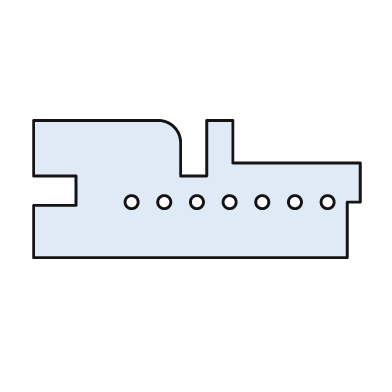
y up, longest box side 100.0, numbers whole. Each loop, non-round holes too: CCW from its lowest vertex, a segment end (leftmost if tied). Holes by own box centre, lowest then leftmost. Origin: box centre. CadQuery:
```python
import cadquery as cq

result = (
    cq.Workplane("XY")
    .moveTo(-50.0, -21.0)
    .lineTo(46.0, -21.0)
    .lineTo(46.0, -4.0)
    .lineTo(50.0, -4.0)
    .lineTo(50.0, 8.0)
    .lineTo(11.0, 8.0)
    .lineTo(11.0, 21.0)
    .lineTo(3.0, 21.0)
    .lineTo(3.0, 4.0)
    .lineTo(-5.0, 4.0)
    .lineTo(-5.0, 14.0)
    .threePointArc((-7.0, 19.0), (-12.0, 21.0))
    .lineTo(-50.0, 21.0)
    .lineTo(-50.0, 4.0)
    .lineTo(-37.0, 4.0)
    .lineTo(-37.0, -5.0)
    .lineTo(-50.0, -5.0)
    .close()
    .moveTo(-20.0, -4.0)
    .circle(2.0)
    .moveTo(-10.0, -4.0)
    .circle(2.0)
    .moveTo(0.0, -4.0)
    .circle(2.0)
    .moveTo(10.0, -4.0)
    .circle(2.0)
    .moveTo(20.0, -4.0)
    .circle(2.0)
    .moveTo(30.0, -4.0)
    .circle(2.0)
    .moveTo(40.0, -4.0)
    .circle(2.0)
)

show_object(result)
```